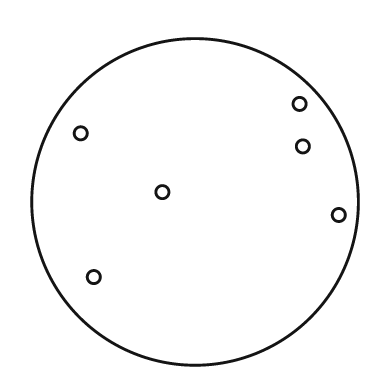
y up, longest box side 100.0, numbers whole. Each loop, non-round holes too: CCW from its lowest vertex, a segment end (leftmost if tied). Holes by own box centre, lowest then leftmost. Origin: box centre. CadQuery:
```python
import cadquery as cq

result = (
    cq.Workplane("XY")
    .moveTo(0.0, 0.0)
    .circle(50.0)
    .moveTo(-31.0, -23.0)
    .circle(2.0)
    .moveTo(44.0, -4.0)
    .circle(2.0)
    .moveTo(-10.0, 3.0)
    .circle(2.0)
    .moveTo(33.0, 17.0)
    .circle(2.0)
    .moveTo(-35.0, 21.0)
    .circle(2.0)
    .moveTo(32.0, 30.0)
    .circle(2.0)
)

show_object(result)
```